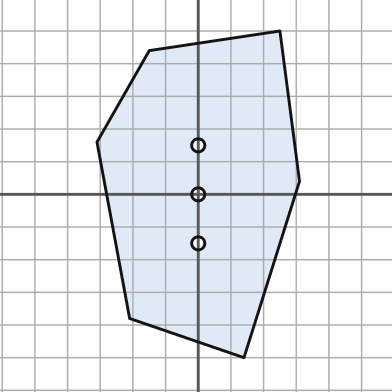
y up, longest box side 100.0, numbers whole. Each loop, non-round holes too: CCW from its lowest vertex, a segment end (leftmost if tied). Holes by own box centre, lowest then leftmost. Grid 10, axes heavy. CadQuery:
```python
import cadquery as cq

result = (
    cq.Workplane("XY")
    .moveTo(14.0, -50.0)
    .lineTo(31.0, 4.0)
    .lineTo(25.0, 50.0)
    .lineTo(-15.0, 44.0)
    .lineTo(-31.0, 16.0)
    .lineTo(-21.0, -38.0)
    .close()
    .moveTo(0.0, -15.0)
    .circle(2.0)
    .moveTo(0.0, 0.0)
    .circle(2.0)
    .moveTo(0.0, 15.0)
    .circle(2.0)
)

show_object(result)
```